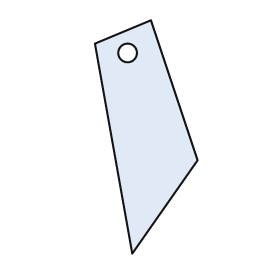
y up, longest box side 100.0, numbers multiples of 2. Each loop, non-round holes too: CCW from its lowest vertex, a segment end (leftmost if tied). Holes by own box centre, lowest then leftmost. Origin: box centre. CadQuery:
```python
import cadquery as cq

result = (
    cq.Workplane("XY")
    .moveTo(-6.0, -50.0)
    .lineTo(22.0, -10.0)
    .lineTo(2.0, 50.0)
    .lineTo(-22.0, 40.0)
    .close()
    .moveTo(-8.0, 36.0)
    .circle(4.0)
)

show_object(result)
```